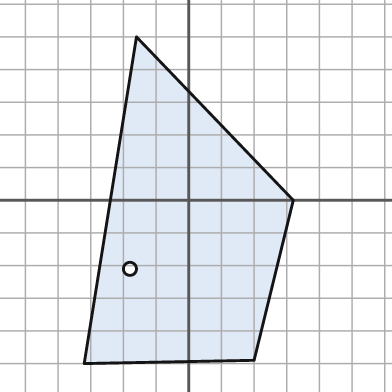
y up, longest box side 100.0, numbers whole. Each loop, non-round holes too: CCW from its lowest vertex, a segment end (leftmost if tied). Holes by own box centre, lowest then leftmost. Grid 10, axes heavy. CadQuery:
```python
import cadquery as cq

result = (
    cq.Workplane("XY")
    .moveTo(-32.0, -50.0)
    .lineTo(20.0, -49.0)
    .lineTo(32.0, 0.0)
    .lineTo(-16.0, 50.0)
    .close()
    .moveTo(-18.0, -21.0)
    .circle(2.0)
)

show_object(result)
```